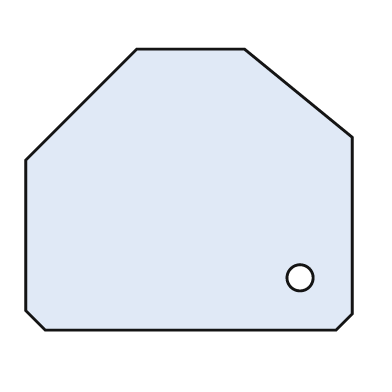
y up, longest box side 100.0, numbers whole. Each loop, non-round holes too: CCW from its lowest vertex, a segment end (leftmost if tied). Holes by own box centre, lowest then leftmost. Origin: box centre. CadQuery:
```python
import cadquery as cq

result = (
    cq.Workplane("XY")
    .moveTo(-44.0, -43.0)
    .lineTo(45.0, -43.0)
    .lineTo(50.0, -38.0)
    .lineTo(50.0, 16.0)
    .lineTo(17.0, 43.0)
    .lineTo(-16.0, 43.0)
    .lineTo(-50.0, 9.0)
    .lineTo(-50.0, -37.0)
    .close()
    .moveTo(34.0, -27.0)
    .circle(4.0)
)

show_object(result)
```